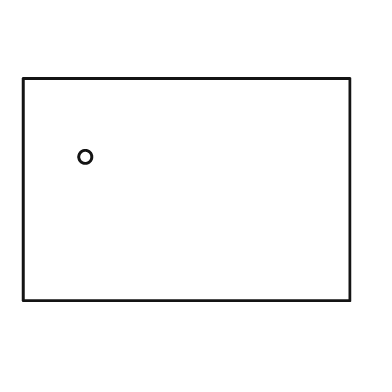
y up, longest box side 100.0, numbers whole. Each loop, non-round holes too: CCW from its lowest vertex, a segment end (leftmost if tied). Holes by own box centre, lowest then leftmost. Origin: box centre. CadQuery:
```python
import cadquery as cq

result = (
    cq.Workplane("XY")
    .moveTo(-50.0, -34.0)
    .lineTo(50.0, -34.0)
    .lineTo(50.0, 34.0)
    .lineTo(-50.0, 34.0)
    .close()
    .moveTo(-31.0, 10.0)
    .circle(2.0)
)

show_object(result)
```